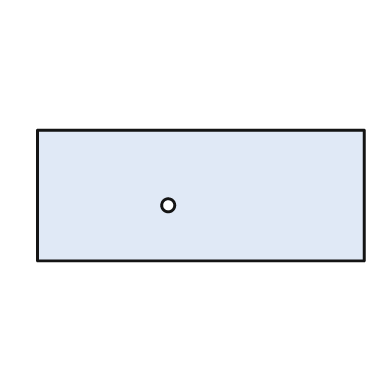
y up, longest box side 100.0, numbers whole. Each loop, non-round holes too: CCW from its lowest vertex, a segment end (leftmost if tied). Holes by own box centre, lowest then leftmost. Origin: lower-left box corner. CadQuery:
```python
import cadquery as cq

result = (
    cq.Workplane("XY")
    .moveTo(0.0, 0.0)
    .lineTo(100.0, 0.0)
    .lineTo(100.0, 40.0)
    .lineTo(0.0, 40.0)
    .close()
    .moveTo(40.0, 17.0)
    .circle(2.0)
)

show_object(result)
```